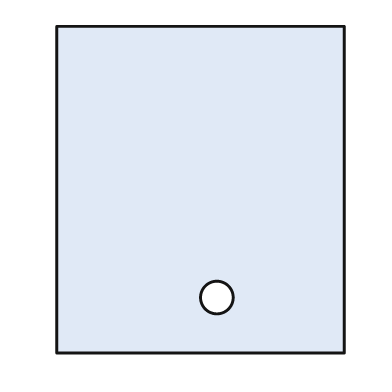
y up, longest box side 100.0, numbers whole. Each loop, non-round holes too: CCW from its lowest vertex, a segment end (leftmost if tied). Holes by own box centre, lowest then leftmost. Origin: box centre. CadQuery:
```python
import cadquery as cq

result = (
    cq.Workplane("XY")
    .moveTo(-44.0, -50.0)
    .lineTo(44.0, -50.0)
    .lineTo(44.0, 50.0)
    .lineTo(-44.0, 50.0)
    .close()
    .moveTo(5.0, -33.0)
    .circle(5.0)
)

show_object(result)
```